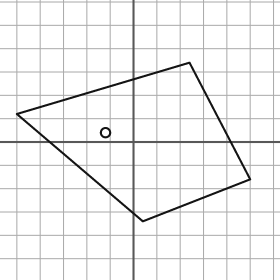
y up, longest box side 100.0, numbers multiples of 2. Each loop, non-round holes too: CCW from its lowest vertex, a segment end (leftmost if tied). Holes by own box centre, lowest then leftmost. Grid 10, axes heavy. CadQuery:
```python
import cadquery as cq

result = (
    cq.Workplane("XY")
    .moveTo(4.0, -34.0)
    .lineTo(50.0, -16.0)
    .lineTo(24.0, 34.0)
    .lineTo(-50.0, 12.0)
    .close()
    .moveTo(-12.0, 4.0)
    .circle(2.0)
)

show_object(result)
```